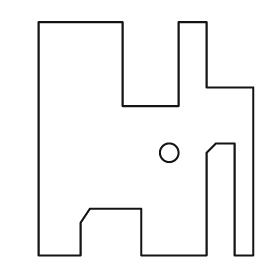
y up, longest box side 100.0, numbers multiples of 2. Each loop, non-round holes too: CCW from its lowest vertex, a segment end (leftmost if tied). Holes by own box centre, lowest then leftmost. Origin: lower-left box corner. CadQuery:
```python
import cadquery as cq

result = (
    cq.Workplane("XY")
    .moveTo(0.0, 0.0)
    .lineTo(18.0, 0.0)
    .lineTo(18.0, 14.0)
    .lineTo(22.0, 20.0)
    .lineTo(44.0, 20.0)
    .lineTo(44.0, 0.0)
    .lineTo(72.0, 0.0)
    .lineTo(72.0, 44.0)
    .lineTo(76.0, 48.0)
    .lineTo(84.0, 48.0)
    .lineTo(84.0, 0.0)
    .lineTo(92.0, 0.0)
    .lineTo(92.0, 72.0)
    .lineTo(72.0, 72.0)
    .lineTo(72.0, 100.0)
    .lineTo(60.0, 100.0)
    .lineTo(60.0, 64.0)
    .lineTo(36.0, 64.0)
    .lineTo(36.0, 100.0)
    .lineTo(0.0, 100.0)
    .close()
    .moveTo(56.0, 44.0)
    .circle(4.0)
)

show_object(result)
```